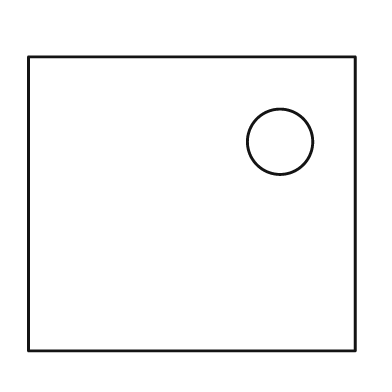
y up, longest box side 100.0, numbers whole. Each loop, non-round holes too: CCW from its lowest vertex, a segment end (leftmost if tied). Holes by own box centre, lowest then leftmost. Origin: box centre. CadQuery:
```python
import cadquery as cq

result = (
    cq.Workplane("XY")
    .moveTo(-50.0, -45.0)
    .lineTo(50.0, -45.0)
    .lineTo(50.0, 45.0)
    .lineTo(-50.0, 45.0)
    .close()
    .moveTo(27.0, 19.0)
    .circle(10.0)
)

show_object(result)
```